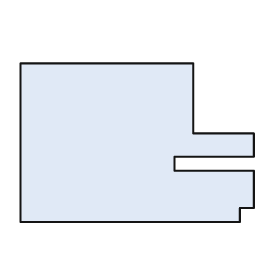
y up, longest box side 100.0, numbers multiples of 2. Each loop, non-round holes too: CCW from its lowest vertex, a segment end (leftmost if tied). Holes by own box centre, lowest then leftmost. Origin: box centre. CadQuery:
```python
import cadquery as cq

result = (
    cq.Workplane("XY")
    .moveTo(-50.0, -34.0)
    .lineTo(44.0, -34.0)
    .lineTo(44.0, -28.0)
    .lineTo(50.0, -28.0)
    .lineTo(50.0, -12.0)
    .lineTo(16.0, -12.0)
    .lineTo(16.0, -6.0)
    .lineTo(50.0, -6.0)
    .lineTo(50.0, 4.0)
    .lineTo(24.0, 4.0)
    .lineTo(24.0, 34.0)
    .lineTo(-50.0, 34.0)
    .close()
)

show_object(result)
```